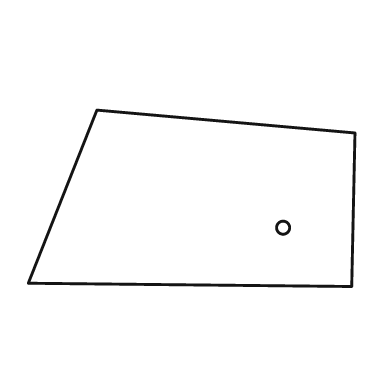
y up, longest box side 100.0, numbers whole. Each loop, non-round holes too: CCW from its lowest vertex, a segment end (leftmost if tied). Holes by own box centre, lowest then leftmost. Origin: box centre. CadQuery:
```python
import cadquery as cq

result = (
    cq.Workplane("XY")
    .moveTo(49.0, -27.0)
    .lineTo(50.0, 20.0)
    .lineTo(-29.0, 27.0)
    .lineTo(-50.0, -26.0)
    .close()
    .moveTo(28.0, -9.0)
    .circle(2.0)
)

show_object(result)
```